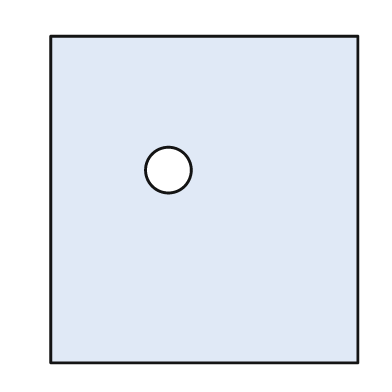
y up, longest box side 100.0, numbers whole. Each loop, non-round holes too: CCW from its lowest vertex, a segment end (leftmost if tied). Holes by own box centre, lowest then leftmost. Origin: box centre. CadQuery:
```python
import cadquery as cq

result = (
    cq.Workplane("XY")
    .moveTo(-47.0, -50.0)
    .lineTo(47.0, -50.0)
    .lineTo(47.0, 50.0)
    .lineTo(-47.0, 50.0)
    .close()
    .moveTo(-11.0, 9.0)
    .circle(7.0)
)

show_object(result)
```